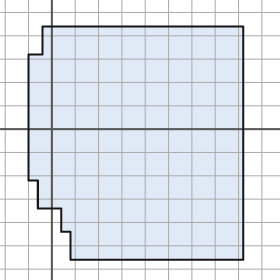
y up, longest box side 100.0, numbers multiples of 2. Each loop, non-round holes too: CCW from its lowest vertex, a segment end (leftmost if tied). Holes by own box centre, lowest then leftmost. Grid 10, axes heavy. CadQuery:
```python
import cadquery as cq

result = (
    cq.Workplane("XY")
    .moveTo(8.0, -56.0)
    .lineTo(82.0, -56.0)
    .lineTo(82.0, 44.0)
    .lineTo(-4.0, 44.0)
    .lineTo(-4.0, 32.0)
    .lineTo(-10.0, 32.0)
    .lineTo(-10.0, -22.0)
    .lineTo(-6.0, -22.0)
    .lineTo(-6.0, -34.0)
    .lineTo(4.0, -34.0)
    .lineTo(4.0, -44.0)
    .lineTo(8.0, -44.0)
    .close()
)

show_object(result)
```